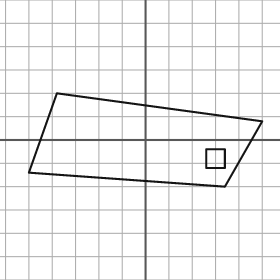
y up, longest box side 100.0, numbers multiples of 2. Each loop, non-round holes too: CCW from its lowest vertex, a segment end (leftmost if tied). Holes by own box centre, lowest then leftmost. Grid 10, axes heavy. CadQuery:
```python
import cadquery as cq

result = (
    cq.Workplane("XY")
    .moveTo(34.0, -20.0)
    .lineTo(50.0, 8.0)
    .lineTo(-38.0, 20.0)
    .lineTo(-50.0, -14.0)
    .close()
    .moveTo(26.0, -12.0)
    .lineTo(34.0, -12.0)
    .lineTo(34.0, -4.0)
    .lineTo(26.0, -4.0)
    .close()
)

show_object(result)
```